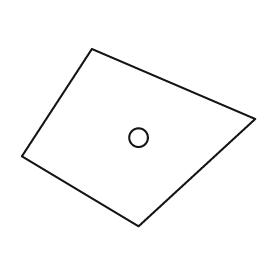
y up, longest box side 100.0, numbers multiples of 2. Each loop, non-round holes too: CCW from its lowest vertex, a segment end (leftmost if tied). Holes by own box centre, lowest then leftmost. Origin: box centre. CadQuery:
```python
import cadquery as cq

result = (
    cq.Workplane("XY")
    .moveTo(0.0, -38.0)
    .lineTo(50.0, 8.0)
    .lineTo(-20.0, 38.0)
    .lineTo(-50.0, -8.0)
    .close()
    .moveTo(0.0, 0.0)
    .circle(4.0)
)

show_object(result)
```